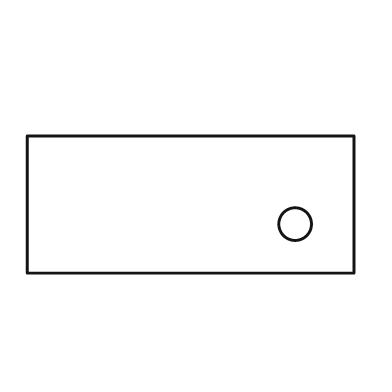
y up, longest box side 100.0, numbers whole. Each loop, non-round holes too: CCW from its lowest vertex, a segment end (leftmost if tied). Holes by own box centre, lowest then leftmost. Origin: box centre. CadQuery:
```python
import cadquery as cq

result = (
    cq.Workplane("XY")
    .moveTo(-50.0, -21.0)
    .lineTo(50.0, -21.0)
    .lineTo(50.0, 21.0)
    .lineTo(-50.0, 21.0)
    .close()
    .moveTo(32.0, -6.0)
    .circle(5.0)
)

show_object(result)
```